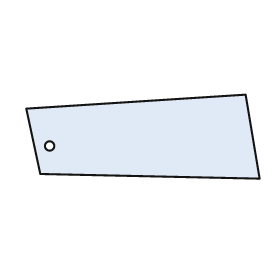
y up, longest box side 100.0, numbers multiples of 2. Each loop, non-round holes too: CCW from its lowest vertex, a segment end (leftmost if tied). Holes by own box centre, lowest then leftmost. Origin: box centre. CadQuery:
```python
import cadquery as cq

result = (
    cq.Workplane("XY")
    .moveTo(50.0, -18.0)
    .lineTo(44.0, 18.0)
    .lineTo(-50.0, 12.0)
    .lineTo(-44.0, -16.0)
    .close()
    .moveTo(-40.0, -4.0)
    .circle(2.0)
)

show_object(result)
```